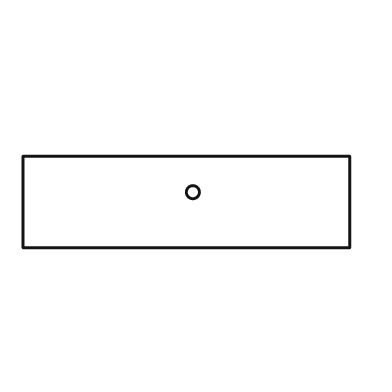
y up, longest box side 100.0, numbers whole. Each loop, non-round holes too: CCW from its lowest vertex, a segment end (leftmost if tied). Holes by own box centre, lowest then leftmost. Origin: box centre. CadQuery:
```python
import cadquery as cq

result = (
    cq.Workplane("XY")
    .moveTo(-50.0, -14.0)
    .lineTo(50.0, -14.0)
    .lineTo(50.0, 14.0)
    .lineTo(-50.0, 14.0)
    .close()
    .moveTo(2.0, 3.0)
    .circle(2.0)
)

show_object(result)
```